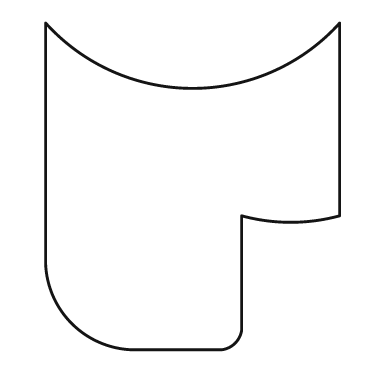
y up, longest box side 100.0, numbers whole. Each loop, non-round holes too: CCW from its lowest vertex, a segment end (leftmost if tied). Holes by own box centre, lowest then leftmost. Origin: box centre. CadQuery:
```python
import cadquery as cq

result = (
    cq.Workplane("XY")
    .moveTo(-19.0, -50.0)
    .lineTo(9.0, -50.0)
    .threePointArc((13.0, -48.0), (15.0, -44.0))
    .lineTo(15.0, -9.0)
    .threePointArc((30.0, -11.0), (45.0, -9.0))
    .lineTo(45.0, 50.0)
    .threePointArc((0.0, 30.0), (-45.0, 50.0))
    .lineTo(-45.0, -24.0)
    .threePointArc((-37.0, -42.0), (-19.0, -50.0))
    .close()
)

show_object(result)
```